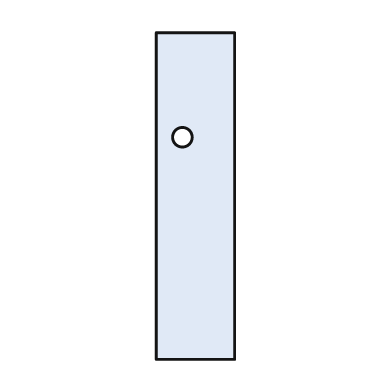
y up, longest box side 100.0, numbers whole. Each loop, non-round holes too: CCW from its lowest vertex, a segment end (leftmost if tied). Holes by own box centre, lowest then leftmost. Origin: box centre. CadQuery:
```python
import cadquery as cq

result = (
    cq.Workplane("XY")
    .moveTo(-12.0, -50.0)
    .lineTo(12.0, -50.0)
    .lineTo(12.0, 50.0)
    .lineTo(-12.0, 50.0)
    .close()
    .moveTo(-4.0, 18.0)
    .circle(3.0)
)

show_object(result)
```